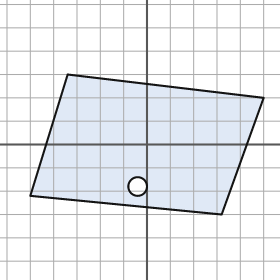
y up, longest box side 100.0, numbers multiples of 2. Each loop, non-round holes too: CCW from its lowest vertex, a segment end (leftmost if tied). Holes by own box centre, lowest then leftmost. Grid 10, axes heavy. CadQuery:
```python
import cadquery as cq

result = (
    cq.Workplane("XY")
    .moveTo(32.0, -30.0)
    .lineTo(50.0, 20.0)
    .lineTo(-34.0, 30.0)
    .lineTo(-50.0, -22.0)
    .close()
    .moveTo(-4.0, -18.0)
    .circle(4.0)
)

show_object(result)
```